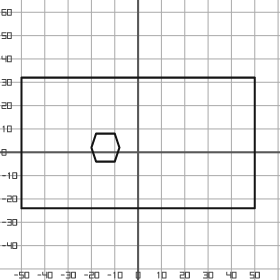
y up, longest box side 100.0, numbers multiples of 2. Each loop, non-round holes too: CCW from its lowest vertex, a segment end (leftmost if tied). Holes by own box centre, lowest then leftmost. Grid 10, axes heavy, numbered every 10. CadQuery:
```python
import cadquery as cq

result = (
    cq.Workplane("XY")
    .moveTo(-50.0, -24.0)
    .lineTo(50.0, -24.0)
    .lineTo(50.0, 32.0)
    .lineTo(-50.0, 32.0)
    .close()
    .moveTo(-18.0, -4.0)
    .lineTo(-10.0, -4.0)
    .lineTo(-8.0, 2.0)
    .lineTo(-10.0, 8.0)
    .lineTo(-18.0, 8.0)
    .lineTo(-20.0, 2.0)
    .close()
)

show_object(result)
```